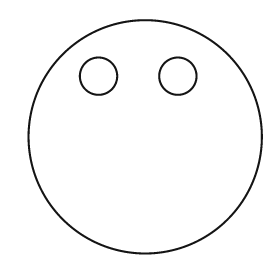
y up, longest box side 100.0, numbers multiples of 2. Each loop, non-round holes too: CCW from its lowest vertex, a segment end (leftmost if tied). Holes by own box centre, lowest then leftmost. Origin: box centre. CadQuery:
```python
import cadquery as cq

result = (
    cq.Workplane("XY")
    .moveTo(0.0, 0.0)
    .circle(50.0)
    .moveTo(-20.0, 26.0)
    .circle(8.0)
    .moveTo(14.0, 26.0)
    .circle(8.0)
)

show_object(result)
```